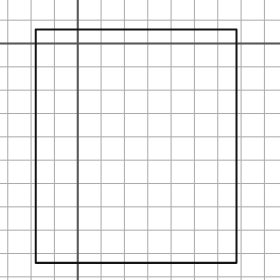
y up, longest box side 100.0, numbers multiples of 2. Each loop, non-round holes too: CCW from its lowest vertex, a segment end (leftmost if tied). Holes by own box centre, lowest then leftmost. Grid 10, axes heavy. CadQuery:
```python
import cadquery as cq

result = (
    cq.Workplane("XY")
    .moveTo(-18.0, -94.0)
    .lineTo(68.0, -94.0)
    .lineTo(68.0, 6.0)
    .lineTo(-18.0, 6.0)
    .close()
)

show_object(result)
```